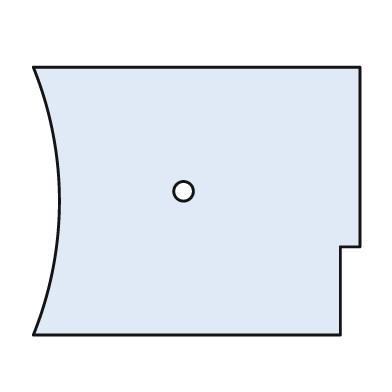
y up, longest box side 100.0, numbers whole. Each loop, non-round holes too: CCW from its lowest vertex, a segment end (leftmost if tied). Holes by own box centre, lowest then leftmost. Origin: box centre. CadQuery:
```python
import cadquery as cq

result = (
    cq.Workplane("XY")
    .moveTo(-50.0, -41.0)
    .lineTo(44.0, -41.0)
    .lineTo(44.0, -14.0)
    .lineTo(50.0, -14.0)
    .lineTo(50.0, 41.0)
    .lineTo(-50.0, 41.0)
    .threePointArc((-42.0, 0.0), (-50.0, -41.0))
    .close()
    .moveTo(-4.0, 3.0)
    .circle(3.0)
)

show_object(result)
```